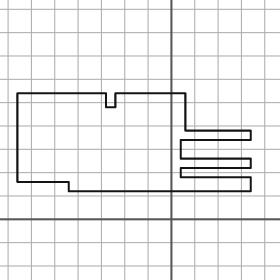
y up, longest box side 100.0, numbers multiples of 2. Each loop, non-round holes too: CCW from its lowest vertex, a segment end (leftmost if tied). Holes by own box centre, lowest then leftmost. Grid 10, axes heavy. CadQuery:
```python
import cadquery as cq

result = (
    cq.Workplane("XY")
    .moveTo(-44.0, 12.0)
    .lineTo(34.0, 12.0)
    .lineTo(34.0, 18.0)
    .lineTo(4.0, 18.0)
    .lineTo(4.0, 22.0)
    .lineTo(34.0, 22.0)
    .lineTo(34.0, 26.0)
    .lineTo(4.0, 26.0)
    .lineTo(4.0, 34.0)
    .lineTo(34.0, 34.0)
    .lineTo(34.0, 38.0)
    .lineTo(6.0, 38.0)
    .lineTo(6.0, 54.0)
    .lineTo(-24.0, 54.0)
    .lineTo(-24.0, 48.0)
    .lineTo(-28.0, 48.0)
    .lineTo(-28.0, 54.0)
    .lineTo(-66.0, 54.0)
    .lineTo(-66.0, 16.0)
    .lineTo(-44.0, 16.0)
    .close()
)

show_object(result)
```